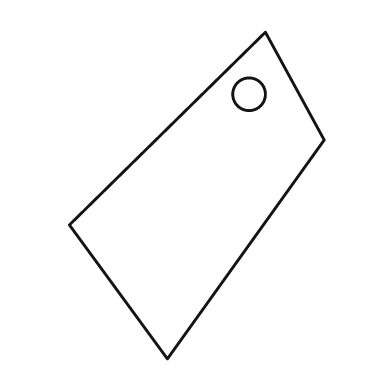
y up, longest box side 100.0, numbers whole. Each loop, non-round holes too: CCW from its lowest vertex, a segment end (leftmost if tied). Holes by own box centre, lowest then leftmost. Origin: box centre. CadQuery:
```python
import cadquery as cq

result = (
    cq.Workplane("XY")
    .moveTo(-9.0, -50.0)
    .lineTo(39.0, 17.0)
    .lineTo(21.0, 50.0)
    .lineTo(-39.0, -9.0)
    .close()
    .moveTo(16.0, 31.0)
    .circle(5.0)
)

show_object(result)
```